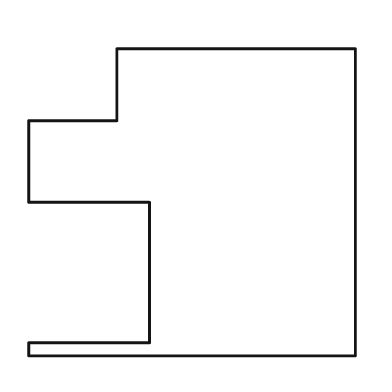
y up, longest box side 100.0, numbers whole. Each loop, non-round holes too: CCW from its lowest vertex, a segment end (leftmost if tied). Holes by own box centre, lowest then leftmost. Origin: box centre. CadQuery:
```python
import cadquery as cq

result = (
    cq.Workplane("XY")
    .moveTo(-50.0, -47.0)
    .lineTo(50.0, -47.0)
    .lineTo(50.0, 47.0)
    .lineTo(-23.0, 47.0)
    .lineTo(-23.0, 25.0)
    .lineTo(-50.0, 25.0)
    .lineTo(-50.0, 0.0)
    .lineTo(-13.0, 0.0)
    .lineTo(-13.0, -43.0)
    .lineTo(-50.0, -43.0)
    .close()
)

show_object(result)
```